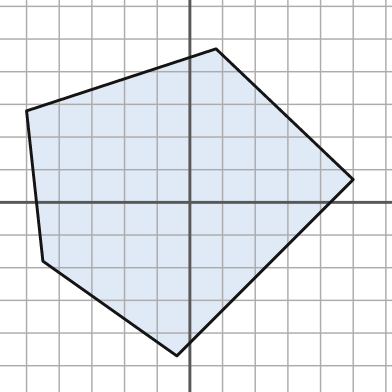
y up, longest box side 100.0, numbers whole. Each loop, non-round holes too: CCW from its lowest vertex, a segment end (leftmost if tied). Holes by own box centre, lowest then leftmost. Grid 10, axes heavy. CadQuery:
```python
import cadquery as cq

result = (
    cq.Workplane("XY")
    .moveTo(-4.0, -47.0)
    .lineTo(50.0, 7.0)
    .lineTo(8.0, 47.0)
    .lineTo(-50.0, 28.0)
    .lineTo(-45.0, -18.0)
    .close()
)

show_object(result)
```